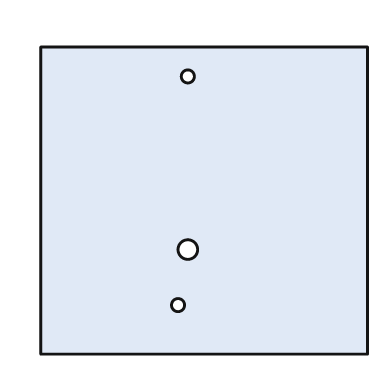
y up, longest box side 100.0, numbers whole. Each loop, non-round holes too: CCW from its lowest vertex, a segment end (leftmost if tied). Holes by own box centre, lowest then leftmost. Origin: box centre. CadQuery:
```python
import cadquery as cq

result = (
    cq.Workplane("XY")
    .moveTo(-50.0, -47.0)
    .lineTo(50.0, -47.0)
    .lineTo(50.0, 47.0)
    .lineTo(-50.0, 47.0)
    .close()
    .moveTo(-8.0, -32.0)
    .circle(2.0)
    .moveTo(-5.0, -15.0)
    .circle(3.0)
    .moveTo(-5.0, 38.0)
    .circle(2.0)
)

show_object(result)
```